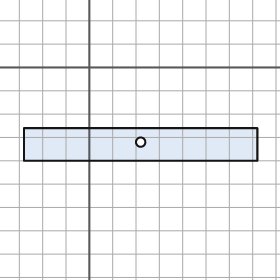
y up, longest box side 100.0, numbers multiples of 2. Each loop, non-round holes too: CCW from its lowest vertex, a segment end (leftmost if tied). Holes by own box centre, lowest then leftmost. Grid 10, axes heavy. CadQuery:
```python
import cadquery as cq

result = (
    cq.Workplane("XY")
    .moveTo(-28.0, -40.0)
    .lineTo(72.0, -40.0)
    .lineTo(72.0, -26.0)
    .lineTo(-28.0, -26.0)
    .close()
    .moveTo(22.0, -32.0)
    .circle(2.0)
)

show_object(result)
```